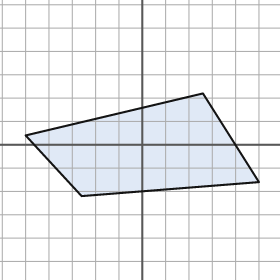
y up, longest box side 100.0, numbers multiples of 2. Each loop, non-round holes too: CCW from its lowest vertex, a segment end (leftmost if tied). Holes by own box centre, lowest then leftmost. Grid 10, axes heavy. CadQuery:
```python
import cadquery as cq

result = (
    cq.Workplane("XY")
    .moveTo(-26.0, -22.0)
    .lineTo(50.0, -16.0)
    .lineTo(26.0, 22.0)
    .lineTo(-50.0, 4.0)
    .close()
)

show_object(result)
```